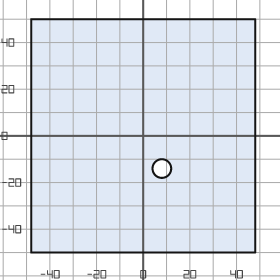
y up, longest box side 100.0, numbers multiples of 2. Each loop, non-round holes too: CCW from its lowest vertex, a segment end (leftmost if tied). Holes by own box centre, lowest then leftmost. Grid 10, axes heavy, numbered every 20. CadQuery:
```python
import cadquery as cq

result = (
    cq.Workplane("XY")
    .moveTo(-48.0, -50.0)
    .lineTo(48.0, -50.0)
    .lineTo(48.0, 50.0)
    .lineTo(-48.0, 50.0)
    .close()
    .moveTo(8.0, -14.0)
    .circle(4.0)
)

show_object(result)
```